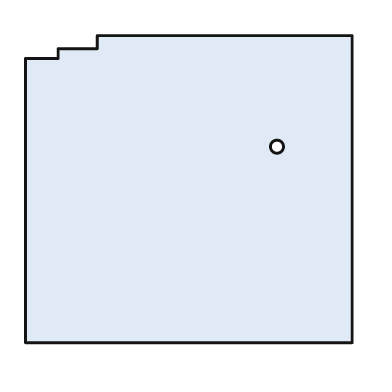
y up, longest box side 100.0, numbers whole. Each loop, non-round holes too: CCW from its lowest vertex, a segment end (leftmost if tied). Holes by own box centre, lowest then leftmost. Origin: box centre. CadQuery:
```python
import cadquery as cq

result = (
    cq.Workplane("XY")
    .moveTo(-50.0, -47.0)
    .lineTo(50.0, -47.0)
    .lineTo(50.0, 47.0)
    .lineTo(-28.0, 47.0)
    .lineTo(-28.0, 43.0)
    .lineTo(-40.0, 43.0)
    .lineTo(-40.0, 40.0)
    .lineTo(-50.0, 40.0)
    .close()
    .moveTo(27.0, 13.0)
    .circle(2.0)
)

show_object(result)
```